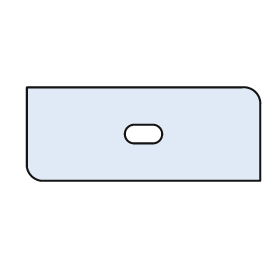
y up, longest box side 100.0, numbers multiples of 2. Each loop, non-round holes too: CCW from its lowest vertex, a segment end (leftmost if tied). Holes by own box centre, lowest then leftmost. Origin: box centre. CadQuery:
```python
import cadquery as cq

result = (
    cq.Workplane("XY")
    .moveTo(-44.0, -20.0)
    .lineTo(50.0, -20.0)
    .lineTo(50.0, 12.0)
    .threePointArc((48.0, 18.0), (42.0, 20.0))
    .lineTo(-50.0, 20.0)
    .lineTo(-50.0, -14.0)
    .threePointArc((-48.0, -18.0), (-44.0, -20.0))
    .close()
    .moveTo(-4.0, -4.0)
    .lineTo(4.0, -4.0)
    .threePointArc((8.0, 0.0), (4.0, 4.0))
    .lineTo(-4.0, 4.0)
    .threePointArc((-8.0, 0.0), (-4.0, -4.0))
    .close()
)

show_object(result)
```